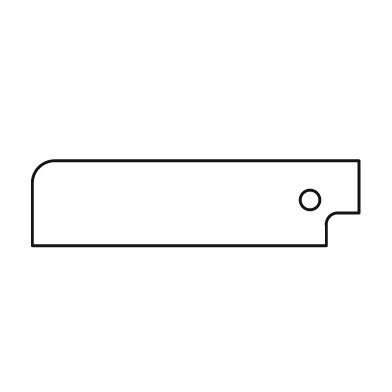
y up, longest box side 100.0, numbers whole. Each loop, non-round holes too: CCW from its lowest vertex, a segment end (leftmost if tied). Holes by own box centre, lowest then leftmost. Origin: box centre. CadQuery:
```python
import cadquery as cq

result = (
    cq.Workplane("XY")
    .moveTo(-50.0, -13.0)
    .lineTo(40.0, -13.0)
    .lineTo(40.0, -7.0)
    .threePointArc((41.0, -4.0), (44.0, -3.0))
    .lineTo(50.0, -3.0)
    .lineTo(50.0, 13.0)
    .lineTo(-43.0, 13.0)
    .threePointArc((-48.0, 11.0), (-50.0, 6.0))
    .close()
    .moveTo(35.0, 1.0)
    .circle(3.0)
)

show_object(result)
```